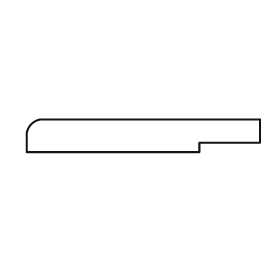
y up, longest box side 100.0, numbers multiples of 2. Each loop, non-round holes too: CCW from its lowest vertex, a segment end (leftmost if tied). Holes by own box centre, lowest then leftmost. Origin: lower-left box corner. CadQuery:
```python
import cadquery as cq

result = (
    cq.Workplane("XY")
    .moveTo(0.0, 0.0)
    .lineTo(74.0, 0.0)
    .lineTo(74.0, 4.0)
    .lineTo(100.0, 4.0)
    .lineTo(100.0, 14.0)
    .lineTo(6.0, 14.0)
    .threePointArc((2.0, 12.0), (0.0, 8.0))
    .close()
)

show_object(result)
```